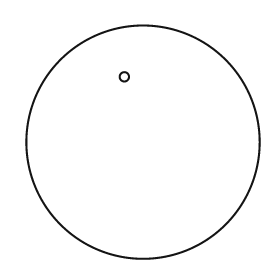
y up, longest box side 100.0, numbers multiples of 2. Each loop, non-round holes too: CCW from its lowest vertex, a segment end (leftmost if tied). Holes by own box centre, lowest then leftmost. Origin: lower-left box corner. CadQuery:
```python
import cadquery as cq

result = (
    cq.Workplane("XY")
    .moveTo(50.0, 50.0)
    .circle(50.0)
    .moveTo(42.0, 78.0)
    .circle(2.0)
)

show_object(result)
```